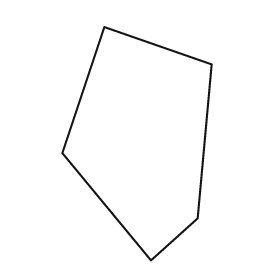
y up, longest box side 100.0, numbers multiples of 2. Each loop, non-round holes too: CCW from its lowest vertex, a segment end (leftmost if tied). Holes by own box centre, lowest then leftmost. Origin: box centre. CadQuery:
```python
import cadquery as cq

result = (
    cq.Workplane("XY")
    .moveTo(6.0, -50.0)
    .lineTo(26.0, -32.0)
    .lineTo(32.0, 34.0)
    .lineTo(-14.0, 50.0)
    .lineTo(-32.0, -4.0)
    .close()
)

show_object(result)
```